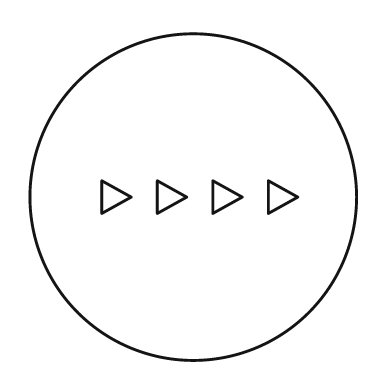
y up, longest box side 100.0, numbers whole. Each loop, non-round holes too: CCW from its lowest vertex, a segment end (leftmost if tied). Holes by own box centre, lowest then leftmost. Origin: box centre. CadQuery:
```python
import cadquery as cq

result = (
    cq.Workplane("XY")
    .moveTo(0.0, 0.0)
    .circle(50.0)
    .moveTo(-28.0, -5.0)
    .lineTo(-19.0, 0.0)
    .lineTo(-28.0, 5.0)
    .close()
    .moveTo(-11.0, -5.0)
    .lineTo(-2.0, 0.0)
    .lineTo(-11.0, 5.0)
    .close()
    .moveTo(6.0, -5.0)
    .lineTo(15.0, 0.0)
    .lineTo(6.0, 5.0)
    .close()
    .moveTo(23.0, -5.0)
    .lineTo(32.0, 0.0)
    .lineTo(23.0, 5.0)
    .close()
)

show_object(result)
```